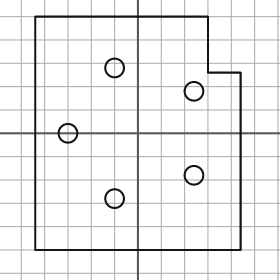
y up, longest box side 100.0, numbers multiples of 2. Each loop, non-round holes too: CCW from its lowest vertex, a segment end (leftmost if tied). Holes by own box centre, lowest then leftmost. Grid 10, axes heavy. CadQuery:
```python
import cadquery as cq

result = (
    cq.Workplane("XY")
    .moveTo(-44.0, -50.0)
    .lineTo(44.0, -50.0)
    .lineTo(44.0, 26.0)
    .lineTo(30.0, 26.0)
    .lineTo(30.0, 50.0)
    .lineTo(-44.0, 50.0)
    .close()
    .moveTo(-10.0, -28.0)
    .circle(4.0)
    .moveTo(24.0, -18.0)
    .circle(4.0)
    .moveTo(-30.0, 0.0)
    .circle(4.0)
    .moveTo(24.0, 18.0)
    .circle(4.0)
    .moveTo(-10.0, 28.0)
    .circle(4.0)
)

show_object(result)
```